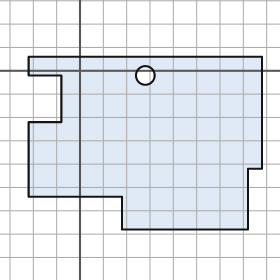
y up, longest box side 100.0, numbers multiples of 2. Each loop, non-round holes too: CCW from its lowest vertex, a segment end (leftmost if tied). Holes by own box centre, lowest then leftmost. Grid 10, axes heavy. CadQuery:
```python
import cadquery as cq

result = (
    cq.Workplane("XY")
    .moveTo(18.0, -68.0)
    .lineTo(72.0, -68.0)
    .lineTo(72.0, -42.0)
    .lineTo(78.0, -42.0)
    .lineTo(78.0, 6.0)
    .lineTo(-22.0, 6.0)
    .lineTo(-22.0, -2.0)
    .lineTo(-8.0, -2.0)
    .lineTo(-8.0, -22.0)
    .lineTo(-22.0, -22.0)
    .lineTo(-22.0, -54.0)
    .lineTo(18.0, -54.0)
    .close()
    .moveTo(28.0, -2.0)
    .circle(4.0)
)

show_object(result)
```